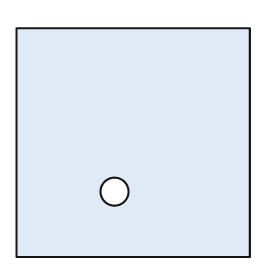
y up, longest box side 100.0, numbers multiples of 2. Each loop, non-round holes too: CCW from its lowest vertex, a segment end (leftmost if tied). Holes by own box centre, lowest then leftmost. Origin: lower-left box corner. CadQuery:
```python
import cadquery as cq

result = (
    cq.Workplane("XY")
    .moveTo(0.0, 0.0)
    .lineTo(100.0, 0.0)
    .lineTo(100.0, 98.0)
    .lineTo(0.0, 98.0)
    .close()
    .moveTo(42.0, 28.0)
    .circle(6.0)
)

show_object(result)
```